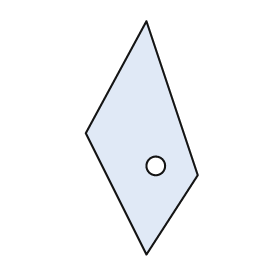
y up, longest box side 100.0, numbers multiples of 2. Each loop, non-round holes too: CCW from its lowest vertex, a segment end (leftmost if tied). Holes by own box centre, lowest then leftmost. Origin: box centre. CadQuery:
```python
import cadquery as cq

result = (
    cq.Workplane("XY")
    .moveTo(2.0, -50.0)
    .lineTo(24.0, -16.0)
    .lineTo(2.0, 50.0)
    .lineTo(-24.0, 2.0)
    .close()
    .moveTo(6.0, -12.0)
    .circle(4.0)
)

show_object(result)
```